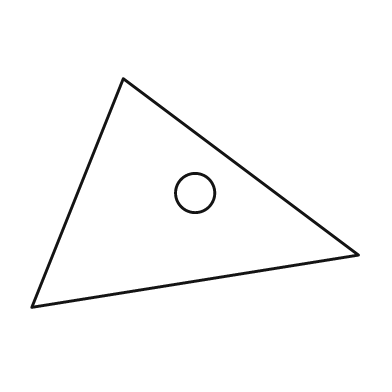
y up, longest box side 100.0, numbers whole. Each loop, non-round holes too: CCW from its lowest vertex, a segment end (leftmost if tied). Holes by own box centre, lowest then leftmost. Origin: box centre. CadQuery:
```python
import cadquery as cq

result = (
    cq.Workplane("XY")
    .moveTo(-50.0, -35.0)
    .lineTo(50.0, -19.0)
    .lineTo(-22.0, 35.0)
    .close()
    .moveTo(0.0, 0.0)
    .circle(6.0)
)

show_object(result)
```